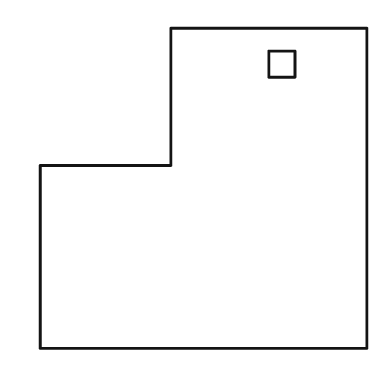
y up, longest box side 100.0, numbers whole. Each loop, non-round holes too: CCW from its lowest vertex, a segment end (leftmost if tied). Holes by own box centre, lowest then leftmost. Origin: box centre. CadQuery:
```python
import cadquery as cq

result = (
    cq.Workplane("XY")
    .moveTo(-50.0, -49.0)
    .lineTo(50.0, -49.0)
    .lineTo(50.0, 49.0)
    .lineTo(-10.0, 49.0)
    .lineTo(-10.0, 7.0)
    .lineTo(-50.0, 7.0)
    .close()
    .moveTo(20.0, 34.0)
    .lineTo(28.0, 34.0)
    .lineTo(28.0, 42.0)
    .lineTo(20.0, 42.0)
    .close()
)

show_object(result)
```